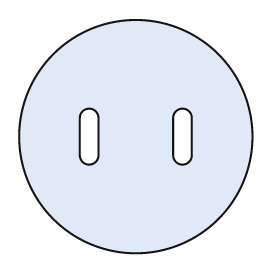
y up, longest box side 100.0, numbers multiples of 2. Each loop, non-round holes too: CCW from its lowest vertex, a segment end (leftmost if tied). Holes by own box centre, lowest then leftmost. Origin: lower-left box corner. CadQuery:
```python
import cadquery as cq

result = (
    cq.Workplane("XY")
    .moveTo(50.0, 50.0)
    .circle(50.0)
    .moveTo(26.0, 42.0)
    .threePointArc((30.0, 38.0), (34.0, 42.0))
    .lineTo(34.0, 58.0)
    .threePointArc((30.0, 62.0), (26.0, 58.0))
    .close()
    .moveTo(66.0, 42.0)
    .threePointArc((70.0, 38.0), (74.0, 42.0))
    .lineTo(74.0, 58.0)
    .threePointArc((70.0, 62.0), (66.0, 58.0))
    .close()
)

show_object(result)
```